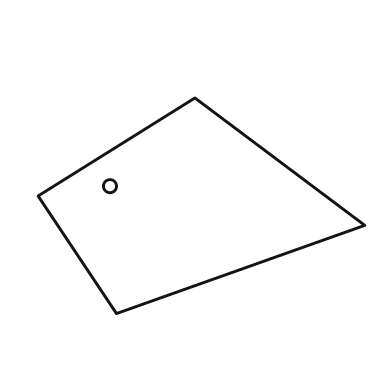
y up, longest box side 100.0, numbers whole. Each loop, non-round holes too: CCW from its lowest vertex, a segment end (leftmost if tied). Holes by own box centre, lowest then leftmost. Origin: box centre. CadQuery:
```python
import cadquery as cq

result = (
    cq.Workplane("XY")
    .moveTo(-26.0, -33.0)
    .lineTo(50.0, -6.0)
    .lineTo(-2.0, 33.0)
    .lineTo(-50.0, 3.0)
    .close()
    .moveTo(-28.0, 6.0)
    .circle(2.0)
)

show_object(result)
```